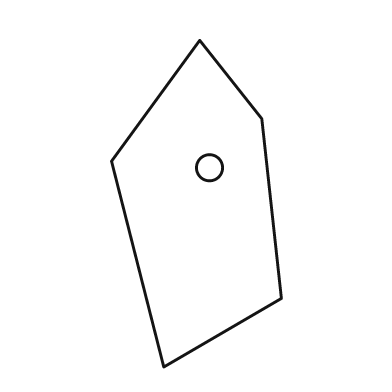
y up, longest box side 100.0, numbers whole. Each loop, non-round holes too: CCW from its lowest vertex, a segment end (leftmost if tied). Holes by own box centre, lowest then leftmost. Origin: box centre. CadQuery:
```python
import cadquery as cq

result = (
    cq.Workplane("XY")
    .moveTo(-10.0, -50.0)
    .lineTo(26.0, -29.0)
    .lineTo(20.0, 26.0)
    .lineTo(1.0, 50.0)
    .lineTo(-26.0, 13.0)
    .close()
    .moveTo(4.0, 11.0)
    .circle(4.0)
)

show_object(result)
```